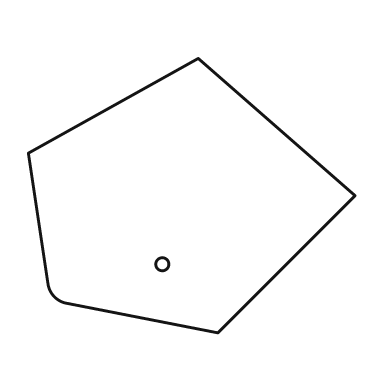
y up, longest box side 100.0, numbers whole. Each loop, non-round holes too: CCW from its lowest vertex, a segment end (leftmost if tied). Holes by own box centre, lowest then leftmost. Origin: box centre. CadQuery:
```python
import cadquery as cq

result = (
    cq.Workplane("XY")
    .moveTo(8.0, -42.0)
    .lineTo(50.0, 0.0)
    .lineTo(2.0, 42.0)
    .lineTo(-50.0, 13.0)
    .lineTo(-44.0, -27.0)
    .threePointArc((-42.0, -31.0), (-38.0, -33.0))
    .close()
    .moveTo(-9.0, -21.0)
    .circle(2.0)
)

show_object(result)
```